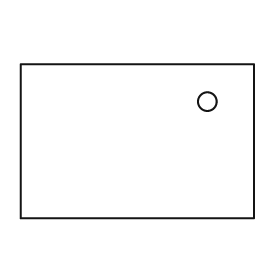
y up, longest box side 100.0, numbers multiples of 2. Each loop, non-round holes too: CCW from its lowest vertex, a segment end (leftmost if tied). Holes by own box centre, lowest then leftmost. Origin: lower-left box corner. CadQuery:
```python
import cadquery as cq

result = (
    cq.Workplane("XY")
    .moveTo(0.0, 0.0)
    .lineTo(100.0, 0.0)
    .lineTo(100.0, 66.0)
    .lineTo(0.0, 66.0)
    .close()
    .moveTo(80.0, 50.0)
    .circle(4.0)
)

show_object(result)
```